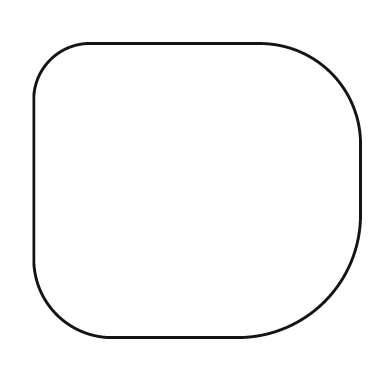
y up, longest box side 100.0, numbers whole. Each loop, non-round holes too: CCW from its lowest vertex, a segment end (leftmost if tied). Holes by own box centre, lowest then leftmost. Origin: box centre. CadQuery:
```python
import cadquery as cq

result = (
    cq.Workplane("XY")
    .moveTo(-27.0, -45.0)
    .lineTo(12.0, -45.0)
    .threePointArc((39.0, -34.0), (50.0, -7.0))
    .lineTo(50.0, 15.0)
    .threePointArc((41.0, 36.0), (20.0, 45.0))
    .lineTo(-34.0, 45.0)
    .threePointArc((-45.0, 40.0), (-50.0, 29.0))
    .lineTo(-50.0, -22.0)
    .threePointArc((-43.0, -38.0), (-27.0, -45.0))
    .close()
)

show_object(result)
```